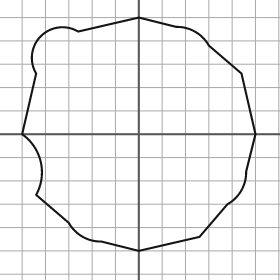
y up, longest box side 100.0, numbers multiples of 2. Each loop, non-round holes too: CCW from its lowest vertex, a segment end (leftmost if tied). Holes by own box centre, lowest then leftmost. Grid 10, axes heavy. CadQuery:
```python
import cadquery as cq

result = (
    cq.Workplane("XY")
    .moveTo(0.0, -50.0)
    .lineTo(26.0, -44.0)
    .lineTo(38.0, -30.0)
    .threePointArc((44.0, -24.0), (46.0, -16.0))
    .lineTo(50.0, 0.0)
    .lineTo(44.0, 26.0)
    .lineTo(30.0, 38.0)
    .threePointArc((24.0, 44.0), (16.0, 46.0))
    .lineTo(0.0, 50.0)
    .lineTo(-26.0, 44.0)
    .threePointArc((-42.0, 42.0), (-44.0, 26.0))
    .lineTo(-50.0, 0.0)
    .threePointArc((-42.0, -12.0), (-44.0, -26.0))
    .lineTo(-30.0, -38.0)
    .threePointArc((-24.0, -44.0), (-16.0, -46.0))
    .close()
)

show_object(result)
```